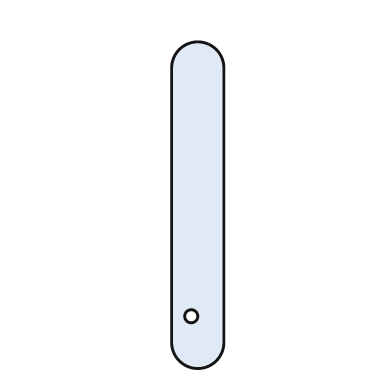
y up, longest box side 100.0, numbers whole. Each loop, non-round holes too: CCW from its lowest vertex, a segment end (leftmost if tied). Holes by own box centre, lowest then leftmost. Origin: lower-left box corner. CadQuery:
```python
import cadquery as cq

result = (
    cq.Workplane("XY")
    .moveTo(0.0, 8.0)
    .threePointArc((8.0, 0.0), (16.0, 8.0))
    .lineTo(16.0, 92.0)
    .threePointArc((8.0, 100.0), (0.0, 92.0))
    .close()
    .moveTo(6.0, 16.0)
    .circle(2.0)
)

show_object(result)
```